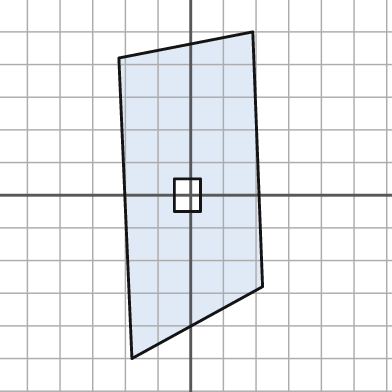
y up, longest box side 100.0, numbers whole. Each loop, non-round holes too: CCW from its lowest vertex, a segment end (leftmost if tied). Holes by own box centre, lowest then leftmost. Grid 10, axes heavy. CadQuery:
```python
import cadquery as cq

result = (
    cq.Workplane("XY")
    .moveTo(-18.0, -50.0)
    .lineTo(22.0, -28.0)
    .lineTo(19.0, 50.0)
    .lineTo(-22.0, 42.0)
    .close()
    .moveTo(-5.0, -5.0)
    .lineTo(3.0, -5.0)
    .lineTo(3.0, 5.0)
    .lineTo(-5.0, 5.0)
    .close()
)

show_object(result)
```